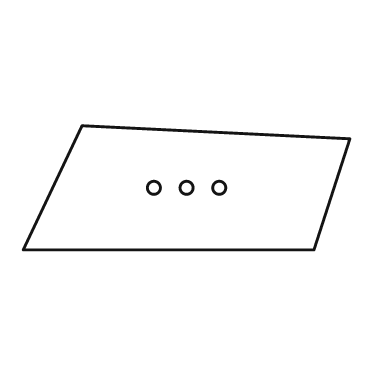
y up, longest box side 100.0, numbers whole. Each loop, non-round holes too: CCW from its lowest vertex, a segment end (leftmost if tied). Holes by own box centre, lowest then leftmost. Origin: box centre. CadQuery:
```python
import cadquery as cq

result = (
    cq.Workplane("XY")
    .moveTo(-50.0, -19.0)
    .lineTo(39.0, -19.0)
    .lineTo(50.0, 15.0)
    .lineTo(-32.0, 19.0)
    .close()
    .moveTo(-10.0, 0.0)
    .circle(2.0)
    .moveTo(0.0, 0.0)
    .circle(2.0)
    .moveTo(10.0, 0.0)
    .circle(2.0)
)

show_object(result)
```